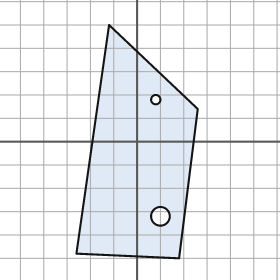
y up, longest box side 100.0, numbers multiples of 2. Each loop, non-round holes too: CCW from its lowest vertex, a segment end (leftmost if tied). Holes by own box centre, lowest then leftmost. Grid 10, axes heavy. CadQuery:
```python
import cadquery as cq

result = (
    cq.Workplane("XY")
    .moveTo(18.0, -50.0)
    .lineTo(26.0, 14.0)
    .lineTo(-12.0, 50.0)
    .lineTo(-26.0, -48.0)
    .close()
    .moveTo(10.0, -32.0)
    .circle(4.0)
    .moveTo(8.0, 18.0)
    .circle(2.0)
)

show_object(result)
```